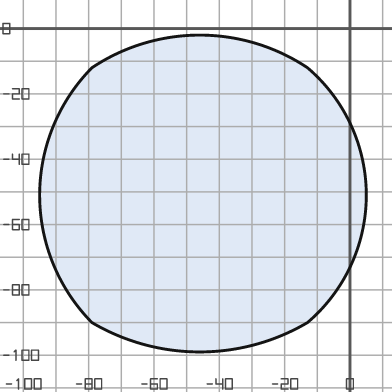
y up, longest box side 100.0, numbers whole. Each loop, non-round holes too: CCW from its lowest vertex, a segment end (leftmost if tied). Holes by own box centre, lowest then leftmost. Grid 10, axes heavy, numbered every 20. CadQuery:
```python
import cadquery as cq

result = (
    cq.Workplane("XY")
    .moveTo(-79.0, -90.0)
    .threePointArc((-46.0, -99.0), (-13.0, -90.0))
    .threePointArc((5.0, -51.0), (-13.0, -12.0))
    .threePointArc((-46.0, -2.0), (-79.0, -12.0))
    .threePointArc((-95.0, -51.0), (-79.0, -90.0))
    .close()
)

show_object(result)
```